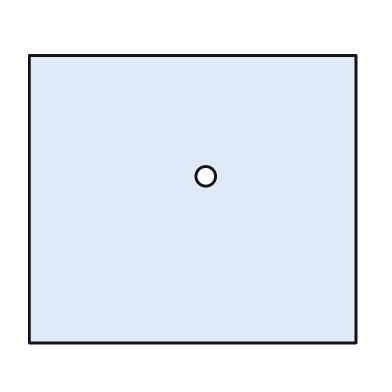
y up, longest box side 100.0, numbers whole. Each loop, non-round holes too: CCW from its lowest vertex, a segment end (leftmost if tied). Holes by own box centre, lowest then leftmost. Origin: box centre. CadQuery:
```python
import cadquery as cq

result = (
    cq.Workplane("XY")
    .moveTo(-50.0, -44.0)
    .lineTo(50.0, -44.0)
    .lineTo(50.0, 44.0)
    .lineTo(-50.0, 44.0)
    .close()
    .moveTo(4.0, 7.0)
    .circle(3.0)
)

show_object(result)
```